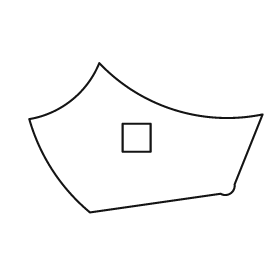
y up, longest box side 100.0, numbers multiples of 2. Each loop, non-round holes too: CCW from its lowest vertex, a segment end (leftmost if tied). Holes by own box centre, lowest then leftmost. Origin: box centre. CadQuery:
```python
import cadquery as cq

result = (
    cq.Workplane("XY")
    .moveTo(-24.0, -32.0)
    .lineTo(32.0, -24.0)
    .threePointArc((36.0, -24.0), (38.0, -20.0))
    .lineTo(50.0, 10.0)
    .threePointArc((12.0, 12.0), (-20.0, 32.0))
    .threePointArc((-32.0, 16.0), (-50.0, 8.0))
    .threePointArc((-40.0, -14.0), (-24.0, -32.0))
    .close()
    .moveTo(-10.0, -6.0)
    .lineTo(2.0, -6.0)
    .lineTo(2.0, 6.0)
    .lineTo(-10.0, 6.0)
    .close()
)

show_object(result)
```